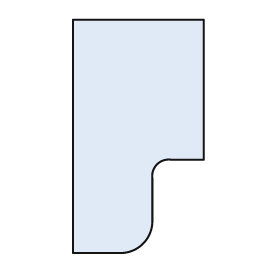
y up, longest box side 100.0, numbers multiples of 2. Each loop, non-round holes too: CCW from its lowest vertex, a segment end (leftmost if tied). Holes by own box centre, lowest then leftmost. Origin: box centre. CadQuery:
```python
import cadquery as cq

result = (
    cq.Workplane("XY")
    .moveTo(-28.0, -50.0)
    .lineTo(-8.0, -50.0)
    .threePointArc((2.0, -46.0), (6.0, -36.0))
    .lineTo(6.0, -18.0)
    .threePointArc((8.0, -12.0), (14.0, -10.0))
    .lineTo(28.0, -10.0)
    .lineTo(28.0, 50.0)
    .lineTo(-28.0, 50.0)
    .close()
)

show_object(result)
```